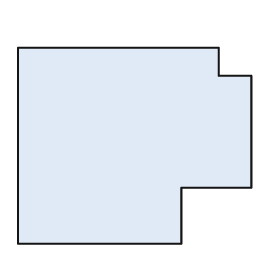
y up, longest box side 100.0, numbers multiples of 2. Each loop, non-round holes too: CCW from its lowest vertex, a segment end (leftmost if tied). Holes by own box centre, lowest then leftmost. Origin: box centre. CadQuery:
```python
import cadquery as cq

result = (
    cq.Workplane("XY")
    .moveTo(-50.0, -42.0)
    .lineTo(20.0, -42.0)
    .lineTo(20.0, -18.0)
    .lineTo(50.0, -18.0)
    .lineTo(50.0, 30.0)
    .lineTo(36.0, 30.0)
    .lineTo(36.0, 42.0)
    .lineTo(-50.0, 42.0)
    .close()
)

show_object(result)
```